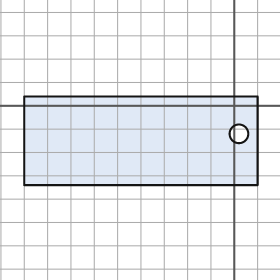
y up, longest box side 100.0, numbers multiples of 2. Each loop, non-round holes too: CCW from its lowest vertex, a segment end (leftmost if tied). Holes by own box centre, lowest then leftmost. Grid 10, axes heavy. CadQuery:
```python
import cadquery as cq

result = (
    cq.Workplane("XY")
    .moveTo(-90.0, -34.0)
    .lineTo(10.0, -34.0)
    .lineTo(10.0, 4.0)
    .lineTo(-90.0, 4.0)
    .close()
    .moveTo(2.0, -12.0)
    .circle(4.0)
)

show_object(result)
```